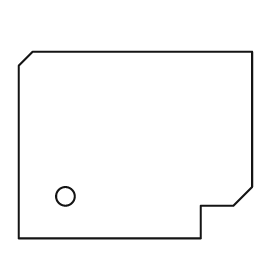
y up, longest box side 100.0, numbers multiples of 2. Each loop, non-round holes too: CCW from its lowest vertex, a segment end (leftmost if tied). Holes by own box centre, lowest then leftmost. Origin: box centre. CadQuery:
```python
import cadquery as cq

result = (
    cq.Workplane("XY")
    .moveTo(-50.0, -40.0)
    .lineTo(28.0, -40.0)
    .lineTo(28.0, -26.0)
    .lineTo(42.0, -26.0)
    .lineTo(50.0, -18.0)
    .lineTo(50.0, 40.0)
    .lineTo(-44.0, 40.0)
    .lineTo(-50.0, 34.0)
    .close()
    .moveTo(-30.0, -22.0)
    .circle(4.0)
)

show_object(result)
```